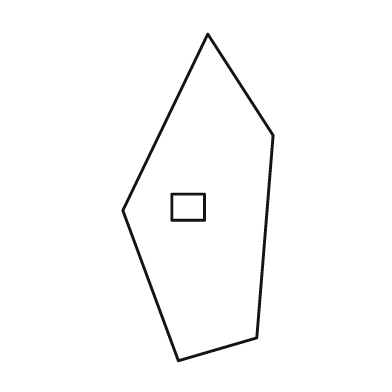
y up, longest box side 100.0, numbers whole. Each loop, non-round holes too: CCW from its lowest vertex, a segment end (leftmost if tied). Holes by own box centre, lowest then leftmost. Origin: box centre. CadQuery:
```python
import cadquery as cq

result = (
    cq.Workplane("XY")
    .moveTo(-6.0, -50.0)
    .lineTo(18.0, -43.0)
    .lineTo(23.0, 19.0)
    .lineTo(3.0, 50.0)
    .lineTo(-23.0, -4.0)
    .close()
    .moveTo(-8.0, -7.0)
    .lineTo(2.0, -7.0)
    .lineTo(2.0, 1.0)
    .lineTo(-8.0, 1.0)
    .close()
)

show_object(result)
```